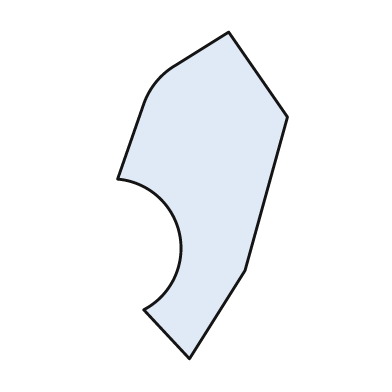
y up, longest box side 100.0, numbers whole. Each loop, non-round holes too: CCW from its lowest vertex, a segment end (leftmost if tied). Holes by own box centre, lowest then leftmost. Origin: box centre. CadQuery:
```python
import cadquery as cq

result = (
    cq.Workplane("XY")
    .moveTo(-4.0, -50.0)
    .lineTo(13.0, -23.0)
    .lineTo(26.0, 24.0)
    .lineTo(8.0, 50.0)
    .lineTo(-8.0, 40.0)
    .threePointArc((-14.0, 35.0), (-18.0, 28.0))
    .lineTo(-26.0, 5.0)
    .threePointArc((-7.0, -12.0), (-18.0, -35.0))
    .close()
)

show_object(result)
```